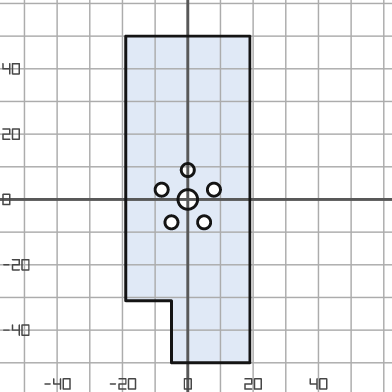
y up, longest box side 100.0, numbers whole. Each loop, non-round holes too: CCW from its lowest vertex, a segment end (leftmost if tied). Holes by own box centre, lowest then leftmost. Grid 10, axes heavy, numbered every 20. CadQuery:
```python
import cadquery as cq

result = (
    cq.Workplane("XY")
    .moveTo(-5.0, -50.0)
    .lineTo(19.0, -50.0)
    .lineTo(19.0, 50.0)
    .lineTo(-19.0, 50.0)
    .lineTo(-19.0, -31.0)
    .lineTo(-5.0, -31.0)
    .close()
    .moveTo(-5.0, -7.0)
    .circle(2.0)
    .moveTo(5.0, -7.0)
    .circle(2.0)
    .moveTo(0.0, 0.0)
    .circle(3.0)
    .moveTo(-8.0, 3.0)
    .circle(2.0)
    .moveTo(8.0, 3.0)
    .circle(2.0)
    .moveTo(0.0, 9.0)
    .circle(2.0)
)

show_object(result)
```